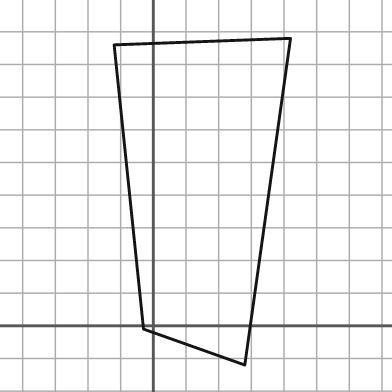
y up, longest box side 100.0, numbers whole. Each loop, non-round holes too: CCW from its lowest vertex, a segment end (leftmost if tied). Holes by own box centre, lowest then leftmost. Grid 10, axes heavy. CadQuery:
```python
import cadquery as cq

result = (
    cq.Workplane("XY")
    .moveTo(28.0, -12.0)
    .lineTo(42.0, 88.0)
    .lineTo(-12.0, 86.0)
    .lineTo(-3.0, -1.0)
    .close()
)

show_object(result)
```